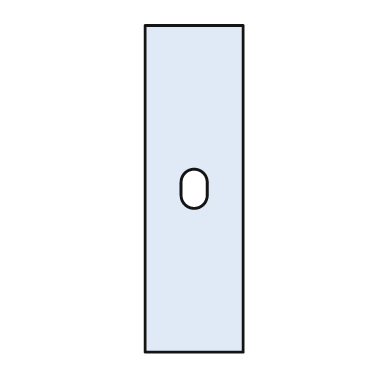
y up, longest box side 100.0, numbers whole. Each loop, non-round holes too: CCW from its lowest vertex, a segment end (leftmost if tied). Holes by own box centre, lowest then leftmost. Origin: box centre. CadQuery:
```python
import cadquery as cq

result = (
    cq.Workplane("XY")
    .moveTo(-15.0, -50.0)
    .lineTo(15.0, -50.0)
    .lineTo(15.0, 50.0)
    .lineTo(-15.0, 50.0)
    .close()
    .moveTo(-4.0, -2.0)
    .threePointArc((0.0, -6.0), (4.0, -2.0))
    .lineTo(4.0, 2.0)
    .threePointArc((0.0, 6.0), (-4.0, 2.0))
    .close()
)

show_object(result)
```